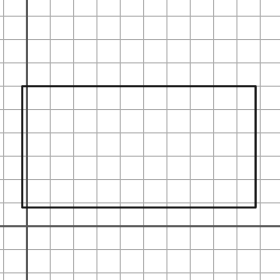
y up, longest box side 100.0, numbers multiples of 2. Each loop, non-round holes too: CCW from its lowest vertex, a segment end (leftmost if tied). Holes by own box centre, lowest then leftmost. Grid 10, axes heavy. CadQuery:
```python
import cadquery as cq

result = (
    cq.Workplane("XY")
    .moveTo(-2.0, 8.0)
    .lineTo(98.0, 8.0)
    .lineTo(98.0, 60.0)
    .lineTo(-2.0, 60.0)
    .close()
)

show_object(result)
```